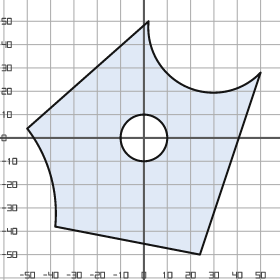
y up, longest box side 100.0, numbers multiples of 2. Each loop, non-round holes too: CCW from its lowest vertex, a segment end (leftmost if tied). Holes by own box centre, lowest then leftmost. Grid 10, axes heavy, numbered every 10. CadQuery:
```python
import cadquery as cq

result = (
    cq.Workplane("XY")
    .moveTo(24.0, -50.0)
    .lineTo(50.0, 28.0)
    .threePointArc((18.0, 22.0), (2.0, 50.0))
    .lineTo(-50.0, 4.0)
    .threePointArc((-40.0, -16.0), (-38.0, -38.0))
    .close()
    .moveTo(0.0, 0.0)
    .circle(10.0)
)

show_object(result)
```